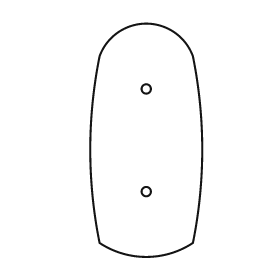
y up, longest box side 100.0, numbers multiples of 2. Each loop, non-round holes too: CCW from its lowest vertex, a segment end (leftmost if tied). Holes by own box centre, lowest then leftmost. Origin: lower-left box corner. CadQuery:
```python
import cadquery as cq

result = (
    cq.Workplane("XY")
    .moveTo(4.0, 6.0)
    .threePointArc((24.0, 0.0), (44.0, 6.0))
    .threePointArc((48.0, 46.0), (44.0, 86.0))
    .threePointArc((24.0, 100.0), (4.0, 86.0))
    .threePointArc((0.0, 46.0), (4.0, 6.0))
    .close()
    .moveTo(24.0, 28.0)
    .circle(2.0)
    .moveTo(24.0, 72.0)
    .circle(2.0)
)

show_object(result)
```